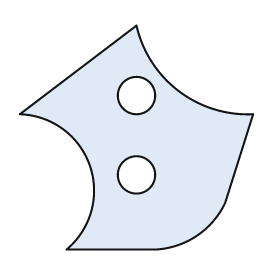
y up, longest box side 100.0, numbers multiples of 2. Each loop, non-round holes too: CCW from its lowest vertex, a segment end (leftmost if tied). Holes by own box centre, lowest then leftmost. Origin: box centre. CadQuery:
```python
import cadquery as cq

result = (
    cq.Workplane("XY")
    .moveTo(-30.0, -48.0)
    .lineTo(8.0, -48.0)
    .threePointArc((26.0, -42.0), (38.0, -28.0))
    .lineTo(50.0, 10.0)
    .threePointArc((18.0, 20.0), (0.0, 48.0))
    .lineTo(-50.0, 10.0)
    .threePointArc((-20.0, -12.0), (-30.0, -48.0))
    .close()
    .moveTo(0.0, -16.0)
    .circle(8.0)
    .moveTo(0.0, 18.0)
    .circle(8.0)
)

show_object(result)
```